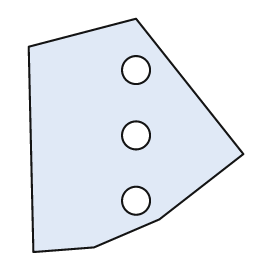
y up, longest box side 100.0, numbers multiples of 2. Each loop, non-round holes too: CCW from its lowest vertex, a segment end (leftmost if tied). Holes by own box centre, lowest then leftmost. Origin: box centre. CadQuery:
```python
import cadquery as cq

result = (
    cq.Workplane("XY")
    .moveTo(-44.0, -50.0)
    .lineTo(-18.0, -48.0)
    .lineTo(10.0, -36.0)
    .lineTo(46.0, -8.0)
    .lineTo(0.0, 50.0)
    .lineTo(-46.0, 38.0)
    .close()
    .moveTo(0.0, -28.0)
    .circle(6.0)
    .moveTo(0.0, 0.0)
    .circle(6.0)
    .moveTo(0.0, 28.0)
    .circle(6.0)
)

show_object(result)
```